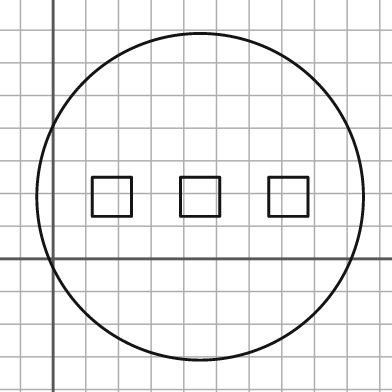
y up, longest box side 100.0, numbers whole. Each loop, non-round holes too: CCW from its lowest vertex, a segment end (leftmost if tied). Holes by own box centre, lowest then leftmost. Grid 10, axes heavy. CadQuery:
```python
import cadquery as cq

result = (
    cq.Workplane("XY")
    .moveTo(45.0, 19.0)
    .circle(50.0)
    .moveTo(12.0, 13.0)
    .lineTo(24.0, 13.0)
    .lineTo(24.0, 25.0)
    .lineTo(12.0, 25.0)
    .close()
    .moveTo(39.0, 13.0)
    .lineTo(51.0, 13.0)
    .lineTo(51.0, 25.0)
    .lineTo(39.0, 25.0)
    .close()
    .moveTo(66.0, 13.0)
    .lineTo(78.0, 13.0)
    .lineTo(78.0, 25.0)
    .lineTo(66.0, 25.0)
    .close()
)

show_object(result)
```